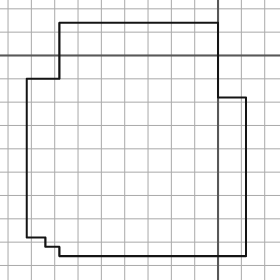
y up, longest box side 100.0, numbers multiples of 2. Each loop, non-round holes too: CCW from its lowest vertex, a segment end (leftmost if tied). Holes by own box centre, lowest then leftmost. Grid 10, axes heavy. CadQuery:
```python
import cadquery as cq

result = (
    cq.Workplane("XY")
    .moveTo(-68.0, -86.0)
    .lineTo(12.0, -86.0)
    .lineTo(12.0, -18.0)
    .lineTo(0.0, -18.0)
    .lineTo(0.0, 14.0)
    .lineTo(-68.0, 14.0)
    .lineTo(-68.0, -10.0)
    .lineTo(-82.0, -10.0)
    .lineTo(-82.0, -78.0)
    .lineTo(-74.0, -78.0)
    .lineTo(-74.0, -82.0)
    .lineTo(-68.0, -82.0)
    .close()
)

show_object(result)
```